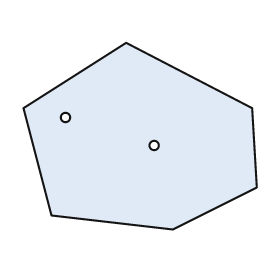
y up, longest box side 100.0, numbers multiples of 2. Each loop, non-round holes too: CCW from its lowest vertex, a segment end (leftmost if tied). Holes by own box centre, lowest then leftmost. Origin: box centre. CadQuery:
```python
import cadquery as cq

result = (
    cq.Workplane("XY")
    .moveTo(14.0, -40.0)
    .lineTo(50.0, -22.0)
    .lineTo(48.0, 12.0)
    .lineTo(-6.0, 40.0)
    .lineTo(-50.0, 12.0)
    .lineTo(-38.0, -34.0)
    .close()
    .moveTo(6.0, -4.0)
    .circle(2.0)
    .moveTo(-32.0, 8.0)
    .circle(2.0)
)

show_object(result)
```